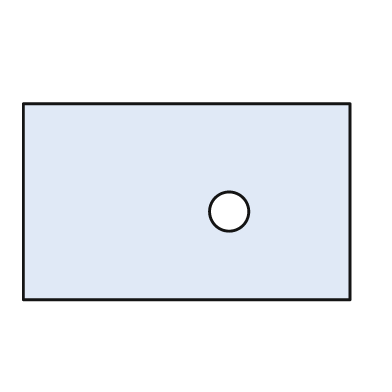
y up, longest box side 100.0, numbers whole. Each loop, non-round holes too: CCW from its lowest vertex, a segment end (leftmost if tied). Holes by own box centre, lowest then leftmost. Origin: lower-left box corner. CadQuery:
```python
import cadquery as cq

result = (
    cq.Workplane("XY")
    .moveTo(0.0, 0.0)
    .lineTo(100.0, 0.0)
    .lineTo(100.0, 60.0)
    .lineTo(0.0, 60.0)
    .close()
    .moveTo(63.0, 27.0)
    .circle(6.0)
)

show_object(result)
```